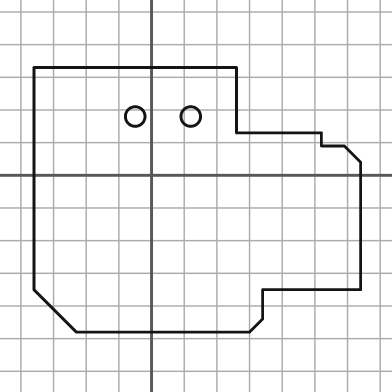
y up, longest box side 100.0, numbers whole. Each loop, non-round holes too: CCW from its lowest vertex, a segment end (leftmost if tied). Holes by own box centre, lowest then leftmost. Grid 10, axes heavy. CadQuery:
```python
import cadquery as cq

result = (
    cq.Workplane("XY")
    .moveTo(-23.0, -48.0)
    .lineTo(30.0, -48.0)
    .lineTo(34.0, -44.0)
    .lineTo(34.0, -35.0)
    .lineTo(64.0, -35.0)
    .lineTo(64.0, 4.0)
    .lineTo(59.0, 9.0)
    .lineTo(52.0, 9.0)
    .lineTo(52.0, 13.0)
    .lineTo(26.0, 13.0)
    .lineTo(26.0, 33.0)
    .lineTo(-36.0, 33.0)
    .lineTo(-36.0, -35.0)
    .close()
    .moveTo(-5.0, 18.0)
    .circle(3.0)
    .moveTo(12.0, 18.0)
    .circle(3.0)
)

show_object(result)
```